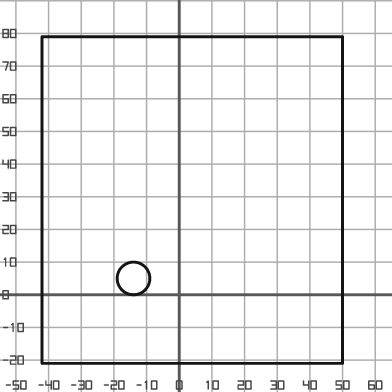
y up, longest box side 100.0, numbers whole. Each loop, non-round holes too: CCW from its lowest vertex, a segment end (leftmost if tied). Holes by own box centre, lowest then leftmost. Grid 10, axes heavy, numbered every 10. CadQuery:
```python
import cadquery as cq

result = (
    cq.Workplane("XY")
    .moveTo(-42.0, -21.0)
    .lineTo(50.0, -21.0)
    .lineTo(50.0, 79.0)
    .lineTo(-42.0, 79.0)
    .close()
    .moveTo(-14.0, 5.0)
    .circle(5.0)
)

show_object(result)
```